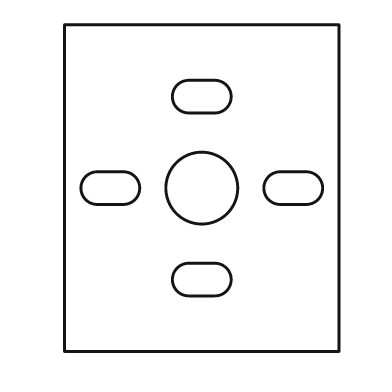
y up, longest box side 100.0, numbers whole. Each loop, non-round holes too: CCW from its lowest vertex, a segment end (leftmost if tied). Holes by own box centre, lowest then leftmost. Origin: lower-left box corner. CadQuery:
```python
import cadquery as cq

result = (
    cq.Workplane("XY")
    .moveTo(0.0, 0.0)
    .lineTo(84.0, 0.0)
    .lineTo(84.0, 100.0)
    .lineTo(0.0, 100.0)
    .close()
    .moveTo(38.0, 17.0)
    .lineTo(46.0, 17.0)
    .threePointArc((51.0, 22.0), (46.0, 27.0))
    .lineTo(38.0, 27.0)
    .threePointArc((33.0, 22.0), (38.0, 17.0))
    .close()
    .moveTo(10.0, 45.0)
    .lineTo(18.0, 45.0)
    .threePointArc((23.0, 50.0), (18.0, 55.0))
    .lineTo(10.0, 55.0)
    .threePointArc((5.0, 50.0), (10.0, 45.0))
    .close()
    .moveTo(42.0, 50.0)
    .circle(11.0)
    .moveTo(66.0, 45.0)
    .lineTo(74.0, 45.0)
    .threePointArc((79.0, 50.0), (74.0, 55.0))
    .lineTo(66.0, 55.0)
    .threePointArc((61.0, 50.0), (66.0, 45.0))
    .close()
    .moveTo(38.0, 73.0)
    .lineTo(46.0, 73.0)
    .threePointArc((51.0, 78.0), (46.0, 83.0))
    .lineTo(38.0, 83.0)
    .threePointArc((33.0, 78.0), (38.0, 73.0))
    .close()
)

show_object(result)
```